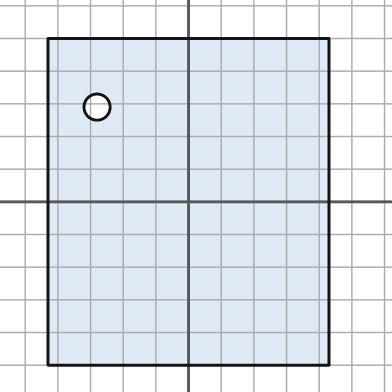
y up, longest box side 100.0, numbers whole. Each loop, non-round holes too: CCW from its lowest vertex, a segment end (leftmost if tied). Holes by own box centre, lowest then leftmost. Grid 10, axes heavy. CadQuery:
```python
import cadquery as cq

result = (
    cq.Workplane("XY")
    .moveTo(-43.0, -50.0)
    .lineTo(43.0, -50.0)
    .lineTo(43.0, 50.0)
    .lineTo(-43.0, 50.0)
    .close()
    .moveTo(-28.0, 29.0)
    .circle(4.0)
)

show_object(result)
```